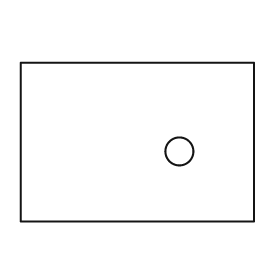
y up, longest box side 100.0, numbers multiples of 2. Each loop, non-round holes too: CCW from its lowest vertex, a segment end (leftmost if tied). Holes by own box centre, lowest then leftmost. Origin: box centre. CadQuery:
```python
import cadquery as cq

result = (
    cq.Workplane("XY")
    .moveTo(-50.0, -34.0)
    .lineTo(50.0, -34.0)
    .lineTo(50.0, 34.0)
    .lineTo(-50.0, 34.0)
    .close()
    .moveTo(18.0, -4.0)
    .circle(6.0)
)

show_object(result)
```